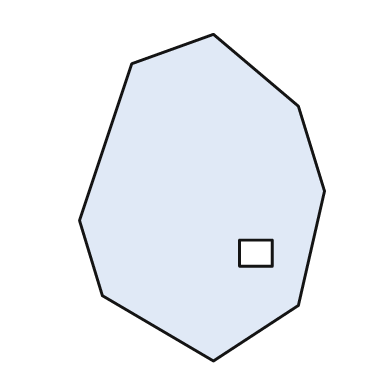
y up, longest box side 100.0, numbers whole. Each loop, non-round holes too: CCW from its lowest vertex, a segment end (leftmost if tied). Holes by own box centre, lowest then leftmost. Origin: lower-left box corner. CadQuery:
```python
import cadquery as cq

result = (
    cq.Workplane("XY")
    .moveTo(41.0, 0.0)
    .lineTo(67.0, 17.0)
    .lineTo(75.0, 52.0)
    .lineTo(67.0, 78.0)
    .lineTo(41.0, 100.0)
    .lineTo(16.0, 91.0)
    .lineTo(0.0, 43.0)
    .lineTo(7.0, 20.0)
    .close()
    .moveTo(49.0, 29.0)
    .lineTo(59.0, 29.0)
    .lineTo(59.0, 37.0)
    .lineTo(49.0, 37.0)
    .close()
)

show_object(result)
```